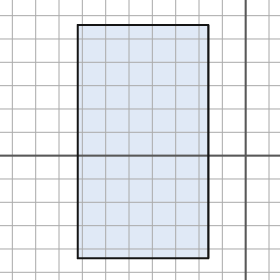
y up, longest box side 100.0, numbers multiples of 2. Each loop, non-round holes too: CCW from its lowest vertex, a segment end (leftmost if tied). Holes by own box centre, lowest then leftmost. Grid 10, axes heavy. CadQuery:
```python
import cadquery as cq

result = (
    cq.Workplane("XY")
    .moveTo(-72.0, -44.0)
    .lineTo(-16.0, -44.0)
    .lineTo(-16.0, 56.0)
    .lineTo(-72.0, 56.0)
    .close()
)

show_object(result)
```